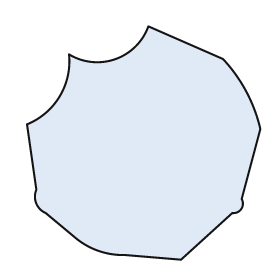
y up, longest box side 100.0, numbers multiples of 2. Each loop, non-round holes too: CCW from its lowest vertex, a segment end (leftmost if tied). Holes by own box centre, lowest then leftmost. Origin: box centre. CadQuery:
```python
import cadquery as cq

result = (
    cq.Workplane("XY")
    .moveTo(16.0, -50.0)
    .lineTo(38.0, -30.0)
    .threePointArc((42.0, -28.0), (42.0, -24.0))
    .lineTo(50.0, 6.0)
    .threePointArc((44.0, 22.0), (34.0, 36.0))
    .lineTo(2.0, 50.0)
    .threePointArc((-12.0, 36.0), (-32.0, 38.0))
    .threePointArc((-36.0, 20.0), (-50.0, 8.0))
    .lineTo(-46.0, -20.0)
    .threePointArc((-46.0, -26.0), (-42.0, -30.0))
    .lineTo(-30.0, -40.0)
    .threePointArc((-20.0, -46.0), (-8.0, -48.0))
    .close()
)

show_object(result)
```